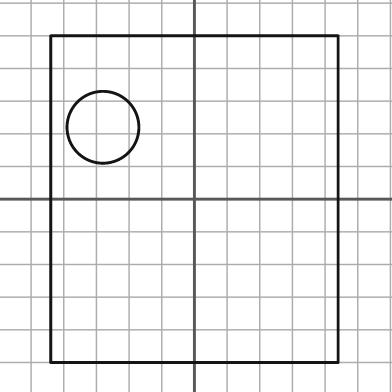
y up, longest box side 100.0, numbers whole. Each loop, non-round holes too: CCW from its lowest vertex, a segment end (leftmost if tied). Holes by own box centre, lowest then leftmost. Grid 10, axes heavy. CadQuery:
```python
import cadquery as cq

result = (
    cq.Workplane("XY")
    .moveTo(-44.0, -50.0)
    .lineTo(44.0, -50.0)
    .lineTo(44.0, 50.0)
    .lineTo(-44.0, 50.0)
    .close()
    .moveTo(-28.0, 22.0)
    .circle(11.0)
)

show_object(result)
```